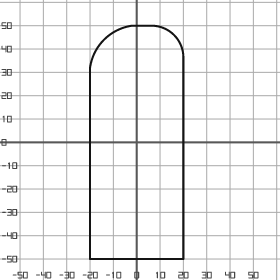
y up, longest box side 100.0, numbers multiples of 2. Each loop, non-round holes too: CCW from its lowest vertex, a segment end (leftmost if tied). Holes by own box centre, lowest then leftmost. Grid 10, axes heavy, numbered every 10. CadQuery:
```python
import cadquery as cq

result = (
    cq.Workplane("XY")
    .moveTo(-20.0, -50.0)
    .lineTo(20.0, -50.0)
    .lineTo(20.0, 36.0)
    .threePointArc((16.0, 46.0), (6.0, 50.0))
    .lineTo(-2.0, 50.0)
    .threePointArc((-14.0, 44.0), (-20.0, 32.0))
    .close()
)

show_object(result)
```